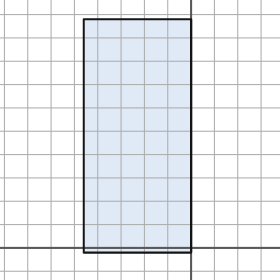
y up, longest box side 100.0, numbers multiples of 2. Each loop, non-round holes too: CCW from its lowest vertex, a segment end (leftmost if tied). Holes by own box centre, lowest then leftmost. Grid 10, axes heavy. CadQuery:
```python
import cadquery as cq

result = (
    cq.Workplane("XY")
    .moveTo(-46.0, -2.0)
    .lineTo(0.0, -2.0)
    .lineTo(0.0, 98.0)
    .lineTo(-46.0, 98.0)
    .close()
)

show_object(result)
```